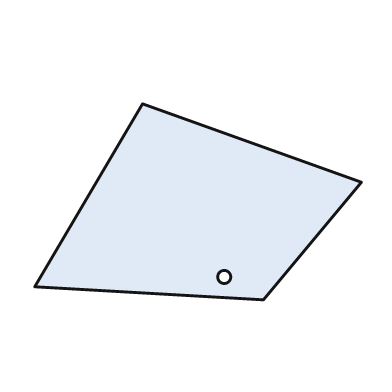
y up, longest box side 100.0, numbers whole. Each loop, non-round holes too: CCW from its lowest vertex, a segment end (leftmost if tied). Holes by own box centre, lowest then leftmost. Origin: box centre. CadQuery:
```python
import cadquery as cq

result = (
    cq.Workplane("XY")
    .moveTo(20.0, -30.0)
    .lineTo(50.0, 6.0)
    .lineTo(-17.0, 30.0)
    .lineTo(-50.0, -26.0)
    .close()
    .moveTo(8.0, -23.0)
    .circle(2.0)
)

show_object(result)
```